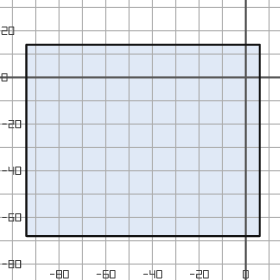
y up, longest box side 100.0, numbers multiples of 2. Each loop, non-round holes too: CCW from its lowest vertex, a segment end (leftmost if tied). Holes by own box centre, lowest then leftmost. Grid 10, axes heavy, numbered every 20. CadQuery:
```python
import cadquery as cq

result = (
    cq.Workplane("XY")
    .moveTo(-94.0, -68.0)
    .lineTo(6.0, -68.0)
    .lineTo(6.0, 14.0)
    .lineTo(-94.0, 14.0)
    .close()
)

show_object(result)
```